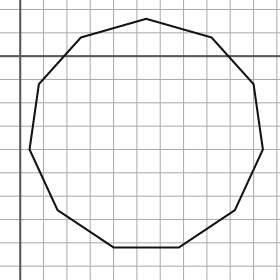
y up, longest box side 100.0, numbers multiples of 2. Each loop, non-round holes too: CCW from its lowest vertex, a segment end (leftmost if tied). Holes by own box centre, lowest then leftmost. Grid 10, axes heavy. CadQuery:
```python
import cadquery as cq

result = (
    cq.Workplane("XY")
    .moveTo(40.0, -82.0)
    .lineTo(68.0, -82.0)
    .lineTo(92.0, -66.0)
    .lineTo(104.0, -40.0)
    .lineTo(100.0, -12.0)
    .lineTo(82.0, 8.0)
    .lineTo(54.0, 16.0)
    .lineTo(26.0, 8.0)
    .lineTo(8.0, -12.0)
    .lineTo(4.0, -40.0)
    .lineTo(16.0, -66.0)
    .close()
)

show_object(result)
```